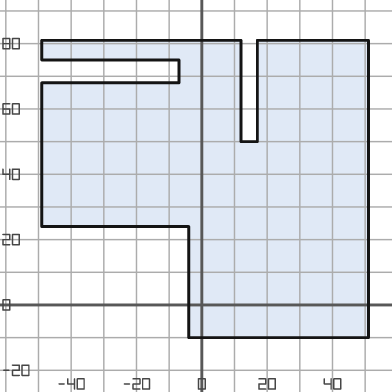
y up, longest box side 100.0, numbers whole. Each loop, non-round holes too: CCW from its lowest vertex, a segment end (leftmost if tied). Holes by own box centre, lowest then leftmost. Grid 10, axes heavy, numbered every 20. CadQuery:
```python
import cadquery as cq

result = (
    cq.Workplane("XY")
    .moveTo(-4.0, -10.0)
    .lineTo(51.0, -10.0)
    .lineTo(51.0, 81.0)
    .lineTo(17.0, 81.0)
    .lineTo(17.0, 50.0)
    .lineTo(12.0, 50.0)
    .lineTo(12.0, 81.0)
    .lineTo(-49.0, 81.0)
    .lineTo(-49.0, 75.0)
    .lineTo(-7.0, 75.0)
    .lineTo(-7.0, 68.0)
    .lineTo(-49.0, 68.0)
    .lineTo(-49.0, 24.0)
    .lineTo(-4.0, 24.0)
    .close()
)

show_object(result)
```